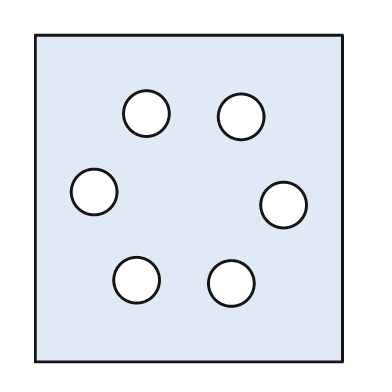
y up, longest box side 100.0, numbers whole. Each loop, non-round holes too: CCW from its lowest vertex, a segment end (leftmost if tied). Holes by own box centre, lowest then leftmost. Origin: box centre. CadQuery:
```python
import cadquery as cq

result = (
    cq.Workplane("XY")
    .moveTo(-47.0, -50.0)
    .lineTo(47.0, -50.0)
    .lineTo(47.0, 50.0)
    .lineTo(-47.0, 50.0)
    .close()
    .moveTo(13.0, -26.0)
    .circle(7.0)
    .moveTo(-16.0, -25.0)
    .circle(7.0)
    .moveTo(29.0, -2.0)
    .circle(7.0)
    .moveTo(-29.0, 2.0)
    .circle(7.0)
    .moveTo(16.0, 25.0)
    .circle(7.0)
    .moveTo(-13.0, 26.0)
    .circle(7.0)
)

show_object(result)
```